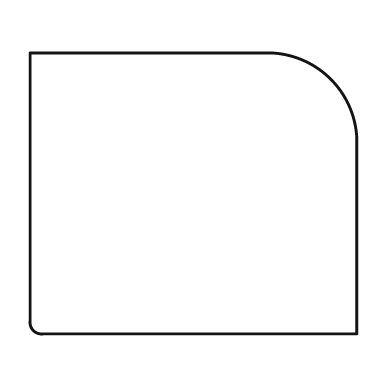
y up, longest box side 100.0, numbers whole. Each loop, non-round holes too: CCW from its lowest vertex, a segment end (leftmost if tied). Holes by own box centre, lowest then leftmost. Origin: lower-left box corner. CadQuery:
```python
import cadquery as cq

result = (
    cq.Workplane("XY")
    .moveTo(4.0, 0.0)
    .lineTo(100.0, 0.0)
    .lineTo(100.0, 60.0)
    .threePointArc((92.0, 78.0), (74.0, 86.0))
    .lineTo(0.0, 86.0)
    .lineTo(0.0, 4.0)
    .threePointArc((1.0, 1.0), (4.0, 0.0))
    .close()
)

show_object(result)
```